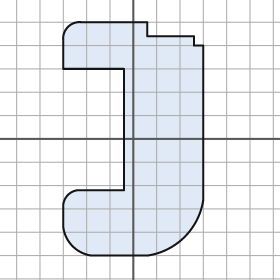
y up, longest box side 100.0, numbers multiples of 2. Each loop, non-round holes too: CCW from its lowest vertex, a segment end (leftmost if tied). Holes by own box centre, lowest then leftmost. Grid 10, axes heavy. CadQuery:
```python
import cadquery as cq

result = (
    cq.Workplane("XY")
    .moveTo(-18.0, -50.0)
    .lineTo(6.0, -50.0)
    .threePointArc((22.0, -42.0), (30.0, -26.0))
    .lineTo(30.0, 40.0)
    .lineTo(26.0, 40.0)
    .lineTo(26.0, 44.0)
    .lineTo(6.0, 44.0)
    .lineTo(6.0, 50.0)
    .lineTo(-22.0, 50.0)
    .threePointArc((-28.0, 48.0), (-30.0, 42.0))
    .lineTo(-30.0, 30.0)
    .lineTo(-4.0, 30.0)
    .lineTo(-4.0, -22.0)
    .lineTo(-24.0, -22.0)
    .threePointArc((-28.0, -24.0), (-30.0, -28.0))
    .lineTo(-30.0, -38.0)
    .threePointArc((-26.0, -46.0), (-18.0, -50.0))
    .close()
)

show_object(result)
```